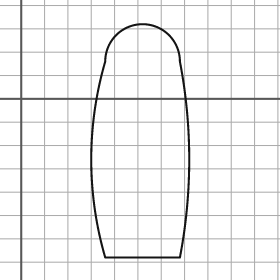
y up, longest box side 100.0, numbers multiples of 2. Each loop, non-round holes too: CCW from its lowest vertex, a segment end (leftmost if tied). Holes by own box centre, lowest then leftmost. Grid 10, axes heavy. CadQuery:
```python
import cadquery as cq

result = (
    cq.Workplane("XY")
    .moveTo(36.0, -68.0)
    .lineTo(68.0, -68.0)
    .threePointArc((72.0, -26.0), (68.0, 16.0))
    .threePointArc((52.0, 32.0), (36.0, 16.0))
    .threePointArc((30.0, -26.0), (36.0, -68.0))
    .close()
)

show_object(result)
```